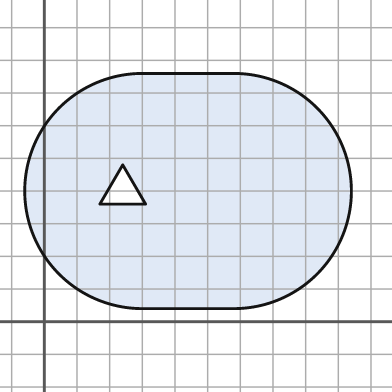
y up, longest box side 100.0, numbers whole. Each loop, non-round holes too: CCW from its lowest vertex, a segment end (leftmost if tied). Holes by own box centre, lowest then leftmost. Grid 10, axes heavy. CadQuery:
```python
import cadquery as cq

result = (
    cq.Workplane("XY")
    .moveTo(30.0, 4.0)
    .lineTo(58.0, 4.0)
    .threePointArc((94.0, 40.0), (58.0, 76.0))
    .lineTo(30.0, 76.0)
    .threePointArc((-6.0, 40.0), (30.0, 4.0))
    .close()
    .moveTo(17.0, 36.0)
    .lineTo(31.0, 36.0)
    .lineTo(24.0, 48.0)
    .close()
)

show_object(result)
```